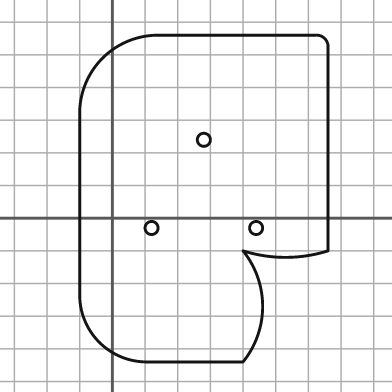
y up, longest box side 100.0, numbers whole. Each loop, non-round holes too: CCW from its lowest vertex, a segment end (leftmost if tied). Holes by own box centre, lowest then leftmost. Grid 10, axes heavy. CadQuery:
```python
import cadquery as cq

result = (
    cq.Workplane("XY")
    .moveTo(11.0, -44.0)
    .lineTo(40.0, -44.0)
    .threePointArc((46.0, -27.0), (40.0, -10.0))
    .threePointArc((53.0, -12.0), (66.0, -10.0))
    .lineTo(66.0, 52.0)
    .threePointArc((65.0, 55.0), (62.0, 56.0))
    .lineTo(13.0, 56.0)
    .threePointArc((-3.0, 49.0), (-10.0, 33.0))
    .lineTo(-10.0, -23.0)
    .threePointArc((-4.0, -38.0), (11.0, -44.0))
    .close()
    .moveTo(12.0, -3.0)
    .circle(2.0)
    .moveTo(44.0, -3.0)
    .circle(2.0)
    .moveTo(28.0, 24.0)
    .circle(2.0)
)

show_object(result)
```